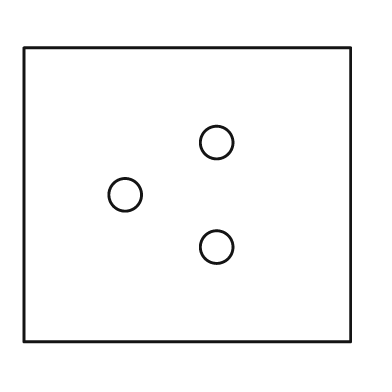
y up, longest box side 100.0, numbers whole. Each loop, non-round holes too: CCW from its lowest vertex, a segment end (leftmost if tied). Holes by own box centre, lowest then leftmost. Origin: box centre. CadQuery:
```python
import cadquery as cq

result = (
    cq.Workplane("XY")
    .moveTo(-50.0, -45.0)
    .lineTo(50.0, -45.0)
    .lineTo(50.0, 45.0)
    .lineTo(-50.0, 45.0)
    .close()
    .moveTo(9.0, -16.0)
    .circle(5.0)
    .moveTo(-19.0, 0.0)
    .circle(5.0)
    .moveTo(9.0, 16.0)
    .circle(5.0)
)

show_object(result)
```